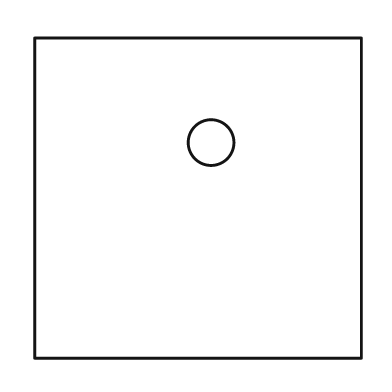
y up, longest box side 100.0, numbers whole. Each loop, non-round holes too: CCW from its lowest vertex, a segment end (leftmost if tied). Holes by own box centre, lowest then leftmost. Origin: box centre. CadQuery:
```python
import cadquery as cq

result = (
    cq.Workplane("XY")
    .moveTo(-50.0, -49.0)
    .lineTo(50.0, -49.0)
    .lineTo(50.0, 49.0)
    .lineTo(-50.0, 49.0)
    .close()
    .moveTo(4.0, 17.0)
    .circle(7.0)
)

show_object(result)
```